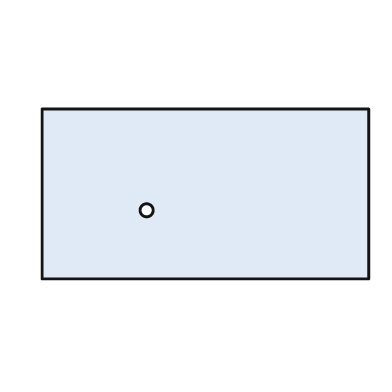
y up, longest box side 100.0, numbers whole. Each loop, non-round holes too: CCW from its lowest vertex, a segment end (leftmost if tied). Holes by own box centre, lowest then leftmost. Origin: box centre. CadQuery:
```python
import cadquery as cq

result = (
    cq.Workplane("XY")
    .moveTo(-50.0, -26.0)
    .lineTo(50.0, -26.0)
    .lineTo(50.0, 26.0)
    .lineTo(-50.0, 26.0)
    .close()
    .moveTo(-18.0, -5.0)
    .circle(2.0)
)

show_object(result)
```